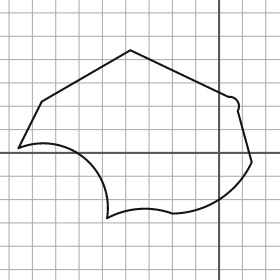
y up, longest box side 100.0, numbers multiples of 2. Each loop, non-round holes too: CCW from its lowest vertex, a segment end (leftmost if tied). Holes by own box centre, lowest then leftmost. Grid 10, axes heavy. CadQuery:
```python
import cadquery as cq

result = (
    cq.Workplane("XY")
    .moveTo(-48.0, -28.0)
    .threePointArc((-34.0, -24.0), (-20.0, -26.0))
    .threePointArc((0.0, -20.0), (14.0, -4.0))
    .lineTo(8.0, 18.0)
    .threePointArc((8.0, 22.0), (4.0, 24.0))
    .lineTo(-38.0, 44.0)
    .lineTo(-76.0, 22.0)
    .lineTo(-86.0, 2.0)
    .threePointArc((-58.0, -2.0), (-48.0, -28.0))
    .close()
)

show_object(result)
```